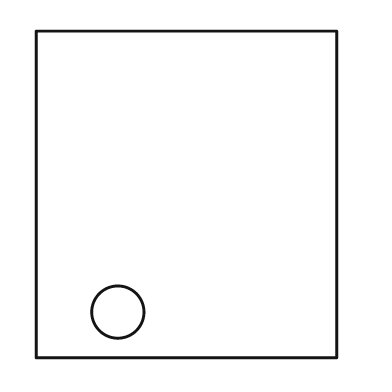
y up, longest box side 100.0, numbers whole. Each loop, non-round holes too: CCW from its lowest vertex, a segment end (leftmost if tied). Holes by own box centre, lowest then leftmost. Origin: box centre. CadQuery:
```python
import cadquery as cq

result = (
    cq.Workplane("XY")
    .moveTo(-46.0, -50.0)
    .lineTo(46.0, -50.0)
    .lineTo(46.0, 50.0)
    .lineTo(-46.0, 50.0)
    .close()
    .moveTo(-21.0, -36.0)
    .circle(8.0)
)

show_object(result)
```